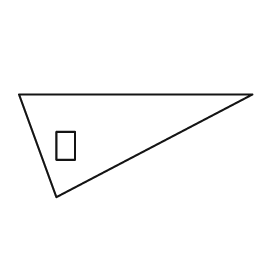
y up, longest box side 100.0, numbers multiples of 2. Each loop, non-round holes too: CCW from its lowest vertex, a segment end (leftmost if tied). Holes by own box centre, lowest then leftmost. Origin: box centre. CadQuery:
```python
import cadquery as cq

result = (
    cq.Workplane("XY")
    .moveTo(-34.0, -22.0)
    .lineTo(50.0, 22.0)
    .lineTo(-50.0, 22.0)
    .close()
    .moveTo(-34.0, -6.0)
    .lineTo(-26.0, -6.0)
    .lineTo(-26.0, 6.0)
    .lineTo(-34.0, 6.0)
    .close()
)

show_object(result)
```